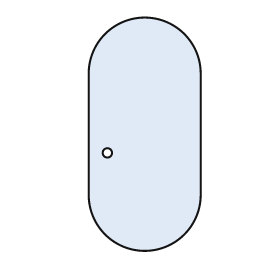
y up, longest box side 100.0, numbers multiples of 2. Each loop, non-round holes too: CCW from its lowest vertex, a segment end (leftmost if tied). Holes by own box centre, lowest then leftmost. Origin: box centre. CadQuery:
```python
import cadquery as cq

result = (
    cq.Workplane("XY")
    .moveTo(-24.0, -26.0)
    .threePointArc((0.0, -50.0), (24.0, -26.0))
    .lineTo(24.0, 26.0)
    .threePointArc((0.0, 50.0), (-24.0, 26.0))
    .close()
    .moveTo(-16.0, -8.0)
    .circle(2.0)
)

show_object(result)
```